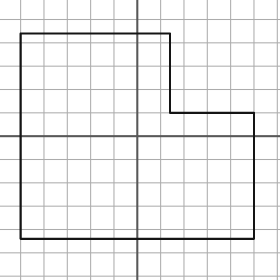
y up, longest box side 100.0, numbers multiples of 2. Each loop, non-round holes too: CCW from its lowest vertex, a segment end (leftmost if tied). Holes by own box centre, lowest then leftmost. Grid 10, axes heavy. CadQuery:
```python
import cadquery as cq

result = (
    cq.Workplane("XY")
    .moveTo(-50.0, -44.0)
    .lineTo(50.0, -44.0)
    .lineTo(50.0, 10.0)
    .lineTo(14.0, 10.0)
    .lineTo(14.0, 44.0)
    .lineTo(-50.0, 44.0)
    .close()
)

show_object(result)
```